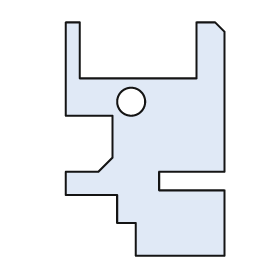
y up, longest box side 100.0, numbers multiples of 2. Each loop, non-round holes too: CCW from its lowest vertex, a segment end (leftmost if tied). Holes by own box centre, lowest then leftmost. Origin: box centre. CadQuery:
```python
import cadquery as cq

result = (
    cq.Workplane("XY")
    .moveTo(-4.0, -50.0)
    .lineTo(34.0, -50.0)
    .lineTo(34.0, -22.0)
    .lineTo(6.0, -22.0)
    .lineTo(6.0, -14.0)
    .lineTo(34.0, -14.0)
    .lineTo(34.0, 46.0)
    .lineTo(30.0, 50.0)
    .lineTo(22.0, 50.0)
    .lineTo(22.0, 26.0)
    .lineTo(-28.0, 26.0)
    .lineTo(-28.0, 50.0)
    .lineTo(-34.0, 50.0)
    .lineTo(-34.0, 10.0)
    .lineTo(-14.0, 10.0)
    .lineTo(-14.0, -8.0)
    .lineTo(-20.0, -14.0)
    .lineTo(-34.0, -14.0)
    .lineTo(-34.0, -24.0)
    .lineTo(-12.0, -24.0)
    .lineTo(-12.0, -36.0)
    .lineTo(-4.0, -36.0)
    .close()
    .moveTo(-6.0, 16.0)
    .circle(6.0)
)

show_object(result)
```